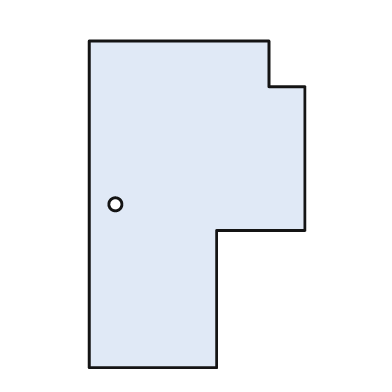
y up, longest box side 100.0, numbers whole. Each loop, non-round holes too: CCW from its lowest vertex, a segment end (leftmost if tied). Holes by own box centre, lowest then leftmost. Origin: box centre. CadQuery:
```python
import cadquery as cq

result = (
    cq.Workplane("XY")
    .moveTo(-33.0, -50.0)
    .lineTo(6.0, -50.0)
    .lineTo(6.0, -8.0)
    .lineTo(33.0, -8.0)
    .lineTo(33.0, 36.0)
    .lineTo(22.0, 36.0)
    .lineTo(22.0, 50.0)
    .lineTo(-33.0, 50.0)
    .close()
    .moveTo(-25.0, 0.0)
    .circle(2.0)
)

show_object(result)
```